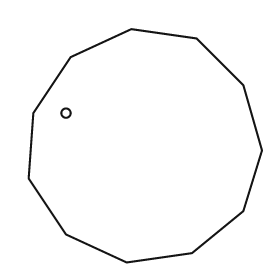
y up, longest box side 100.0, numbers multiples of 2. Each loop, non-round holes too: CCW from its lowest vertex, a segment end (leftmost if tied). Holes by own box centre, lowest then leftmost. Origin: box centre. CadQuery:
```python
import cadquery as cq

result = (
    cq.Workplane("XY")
    .moveTo(-8.0, -50.0)
    .lineTo(20.0, -46.0)
    .lineTo(42.0, -28.0)
    .lineTo(50.0, -2.0)
    .lineTo(42.0, 26.0)
    .lineTo(22.0, 46.0)
    .lineTo(-6.0, 50.0)
    .lineTo(-32.0, 38.0)
    .lineTo(-48.0, 14.0)
    .lineTo(-50.0, -14.0)
    .lineTo(-34.0, -38.0)
    .close()
    .moveTo(-34.0, 14.0)
    .circle(2.0)
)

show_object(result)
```